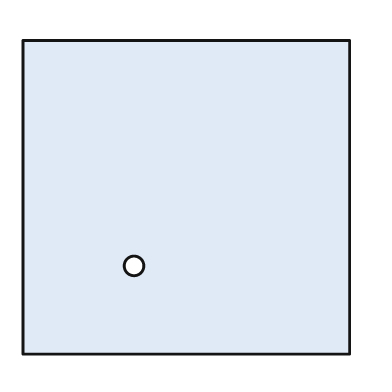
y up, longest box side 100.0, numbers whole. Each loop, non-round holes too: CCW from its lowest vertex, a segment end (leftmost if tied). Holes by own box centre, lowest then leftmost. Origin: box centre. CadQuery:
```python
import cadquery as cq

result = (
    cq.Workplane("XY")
    .moveTo(-50.0, -48.0)
    .lineTo(50.0, -48.0)
    .lineTo(50.0, 48.0)
    .lineTo(-50.0, 48.0)
    .close()
    .moveTo(-16.0, -21.0)
    .circle(3.0)
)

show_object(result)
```